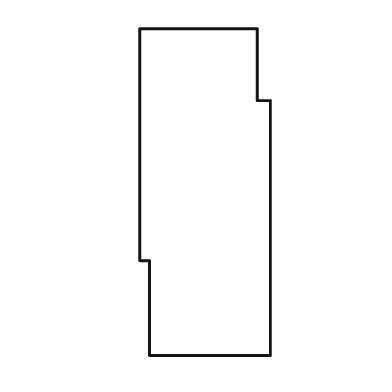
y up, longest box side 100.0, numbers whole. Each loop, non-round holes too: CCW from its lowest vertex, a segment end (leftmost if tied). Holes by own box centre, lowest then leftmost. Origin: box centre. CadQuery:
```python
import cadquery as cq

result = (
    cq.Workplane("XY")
    .moveTo(-17.0, -50.0)
    .lineTo(20.0, -50.0)
    .lineTo(20.0, 28.0)
    .lineTo(16.0, 28.0)
    .lineTo(16.0, 50.0)
    .lineTo(-20.0, 50.0)
    .lineTo(-20.0, -21.0)
    .lineTo(-17.0, -21.0)
    .close()
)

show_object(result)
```